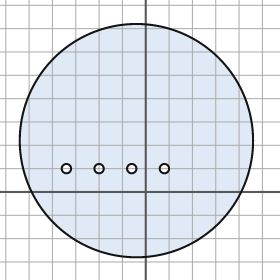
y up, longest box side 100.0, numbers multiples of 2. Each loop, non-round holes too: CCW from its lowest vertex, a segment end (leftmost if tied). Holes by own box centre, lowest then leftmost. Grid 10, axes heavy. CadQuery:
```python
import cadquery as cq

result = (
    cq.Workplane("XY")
    .moveTo(-4.0, 22.0)
    .circle(50.0)
    .moveTo(-34.0, 10.0)
    .circle(2.0)
    .moveTo(-20.0, 10.0)
    .circle(2.0)
    .moveTo(-6.0, 10.0)
    .circle(2.0)
    .moveTo(8.0, 10.0)
    .circle(2.0)
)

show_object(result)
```